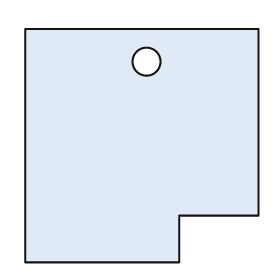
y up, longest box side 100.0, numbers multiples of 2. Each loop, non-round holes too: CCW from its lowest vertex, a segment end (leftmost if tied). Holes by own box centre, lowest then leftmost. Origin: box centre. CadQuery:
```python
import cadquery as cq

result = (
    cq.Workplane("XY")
    .moveTo(-50.0, -50.0)
    .lineTo(16.0, -50.0)
    .lineTo(16.0, -30.0)
    .lineTo(50.0, -30.0)
    .lineTo(50.0, 50.0)
    .lineTo(-50.0, 50.0)
    .close()
    .moveTo(2.0, 36.0)
    .circle(6.0)
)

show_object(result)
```